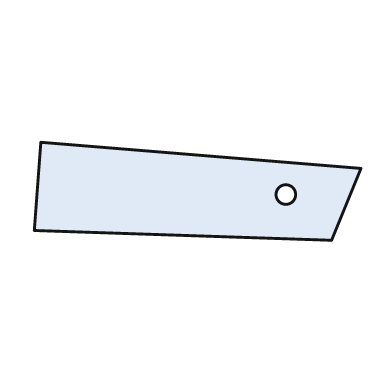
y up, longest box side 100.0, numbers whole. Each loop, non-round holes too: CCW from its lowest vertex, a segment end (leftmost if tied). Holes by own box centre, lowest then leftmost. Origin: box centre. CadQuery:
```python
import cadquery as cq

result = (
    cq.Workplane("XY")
    .moveTo(41.0, -15.0)
    .lineTo(50.0, 7.0)
    .lineTo(-48.0, 15.0)
    .lineTo(-50.0, -12.0)
    .close()
    .moveTo(27.0, -1.0)
    .circle(3.0)
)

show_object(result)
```